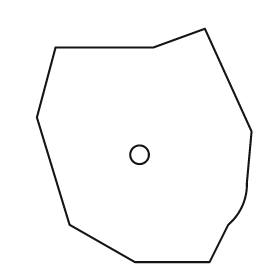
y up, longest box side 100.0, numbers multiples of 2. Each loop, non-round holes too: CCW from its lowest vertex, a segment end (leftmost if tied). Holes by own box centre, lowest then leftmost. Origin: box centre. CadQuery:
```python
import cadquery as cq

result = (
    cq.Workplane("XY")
    .moveTo(-4.0, -50.0)
    .lineTo(28.0, -50.0)
    .lineTo(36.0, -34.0)
    .threePointArc((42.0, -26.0), (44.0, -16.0))
    .lineTo(46.0, 6.0)
    .lineTo(26.0, 50.0)
    .lineTo(4.0, 42.0)
    .lineTo(-38.0, 42.0)
    .lineTo(-46.0, 12.0)
    .lineTo(-32.0, -34.0)
    .close()
    .moveTo(-2.0, -4.0)
    .circle(4.0)
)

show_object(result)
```